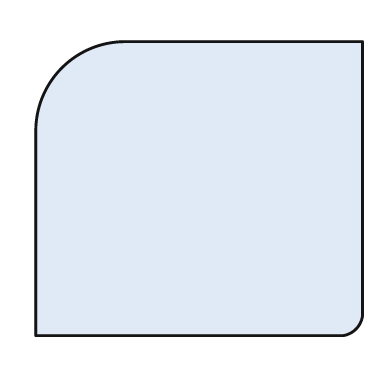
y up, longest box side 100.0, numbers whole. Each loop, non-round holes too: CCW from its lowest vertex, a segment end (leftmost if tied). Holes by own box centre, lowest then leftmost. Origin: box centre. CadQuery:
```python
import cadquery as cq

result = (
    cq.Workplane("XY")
    .moveTo(-50.0, -45.0)
    .lineTo(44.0, -45.0)
    .threePointArc((48.0, -43.0), (50.0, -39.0))
    .lineTo(50.0, 45.0)
    .lineTo(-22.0, 45.0)
    .threePointArc((-42.0, 37.0), (-50.0, 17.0))
    .close()
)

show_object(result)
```